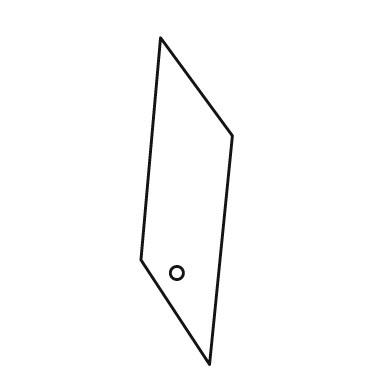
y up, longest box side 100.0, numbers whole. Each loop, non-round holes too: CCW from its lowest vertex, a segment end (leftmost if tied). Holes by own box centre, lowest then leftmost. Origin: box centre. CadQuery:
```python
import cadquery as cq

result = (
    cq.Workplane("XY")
    .moveTo(7.0, -50.0)
    .lineTo(14.0, 20.0)
    .lineTo(-8.0, 50.0)
    .lineTo(-14.0, -18.0)
    .close()
    .moveTo(-3.0, -22.0)
    .circle(2.0)
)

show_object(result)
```